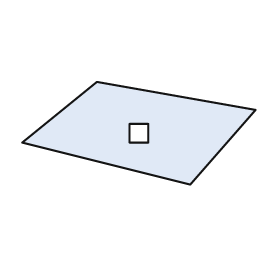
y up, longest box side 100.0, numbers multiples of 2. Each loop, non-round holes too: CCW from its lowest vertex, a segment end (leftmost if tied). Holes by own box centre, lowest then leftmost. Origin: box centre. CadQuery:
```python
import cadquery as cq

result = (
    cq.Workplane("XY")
    .moveTo(22.0, -22.0)
    .lineTo(50.0, 10.0)
    .lineTo(-18.0, 22.0)
    .lineTo(-50.0, -4.0)
    .close()
    .moveTo(-4.0, -4.0)
    .lineTo(4.0, -4.0)
    .lineTo(4.0, 4.0)
    .lineTo(-4.0, 4.0)
    .close()
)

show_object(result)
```